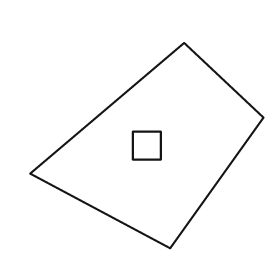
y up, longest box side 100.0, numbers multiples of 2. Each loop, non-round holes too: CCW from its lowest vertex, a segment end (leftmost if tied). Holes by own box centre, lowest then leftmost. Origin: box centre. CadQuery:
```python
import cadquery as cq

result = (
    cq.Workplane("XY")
    .moveTo(10.0, -44.0)
    .lineTo(50.0, 12.0)
    .lineTo(16.0, 44.0)
    .lineTo(-50.0, -12.0)
    .close()
    .moveTo(-6.0, -6.0)
    .lineTo(6.0, -6.0)
    .lineTo(6.0, 6.0)
    .lineTo(-6.0, 6.0)
    .close()
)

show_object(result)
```